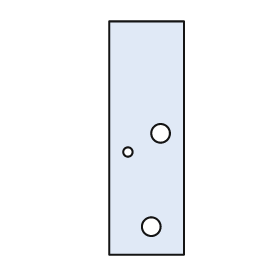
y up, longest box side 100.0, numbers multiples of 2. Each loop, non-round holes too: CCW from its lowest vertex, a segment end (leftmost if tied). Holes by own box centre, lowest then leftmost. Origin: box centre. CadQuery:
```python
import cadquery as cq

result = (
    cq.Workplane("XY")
    .moveTo(-16.0, -50.0)
    .lineTo(16.0, -50.0)
    .lineTo(16.0, 50.0)
    .lineTo(-16.0, 50.0)
    .close()
    .moveTo(2.0, -38.0)
    .circle(4.0)
    .moveTo(-8.0, -6.0)
    .circle(2.0)
    .moveTo(6.0, 2.0)
    .circle(4.0)
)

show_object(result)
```